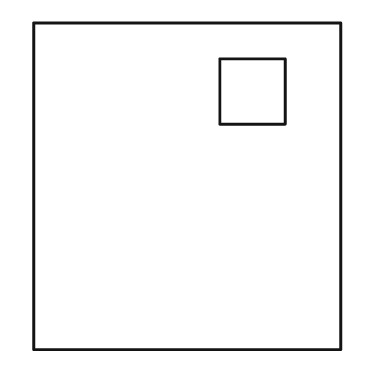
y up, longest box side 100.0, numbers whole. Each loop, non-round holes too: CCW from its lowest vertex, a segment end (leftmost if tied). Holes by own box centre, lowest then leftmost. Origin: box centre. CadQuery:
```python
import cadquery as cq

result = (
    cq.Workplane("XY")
    .moveTo(-47.0, -50.0)
    .lineTo(47.0, -50.0)
    .lineTo(47.0, 50.0)
    .lineTo(-47.0, 50.0)
    .close()
    .moveTo(10.0, 19.0)
    .lineTo(30.0, 19.0)
    .lineTo(30.0, 39.0)
    .lineTo(10.0, 39.0)
    .close()
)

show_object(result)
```